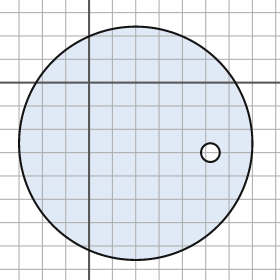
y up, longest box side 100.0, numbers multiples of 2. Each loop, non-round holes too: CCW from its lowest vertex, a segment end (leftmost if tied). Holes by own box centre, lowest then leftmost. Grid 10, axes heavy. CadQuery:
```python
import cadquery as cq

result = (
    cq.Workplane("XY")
    .moveTo(20.0, -26.0)
    .circle(50.0)
    .moveTo(52.0, -30.0)
    .circle(4.0)
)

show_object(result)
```